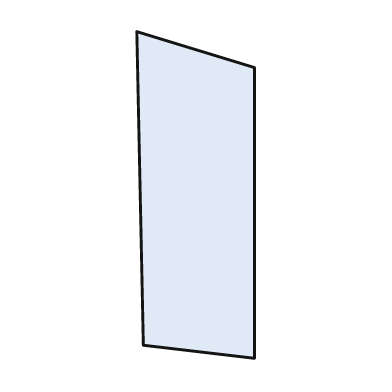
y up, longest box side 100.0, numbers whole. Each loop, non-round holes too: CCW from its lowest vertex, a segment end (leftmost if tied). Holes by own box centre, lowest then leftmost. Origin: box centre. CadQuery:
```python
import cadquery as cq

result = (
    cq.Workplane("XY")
    .moveTo(18.0, -50.0)
    .lineTo(18.0, 39.0)
    .lineTo(-18.0, 50.0)
    .lineTo(-16.0, -46.0)
    .close()
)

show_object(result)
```